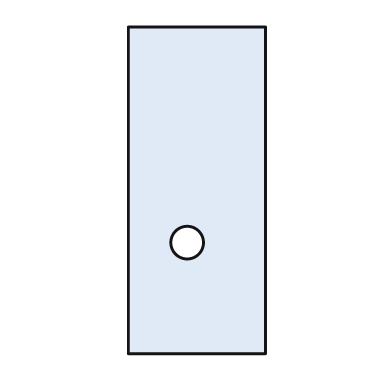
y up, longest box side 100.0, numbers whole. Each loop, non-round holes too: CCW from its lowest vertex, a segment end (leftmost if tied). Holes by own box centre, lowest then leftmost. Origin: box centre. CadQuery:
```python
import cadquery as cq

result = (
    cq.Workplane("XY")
    .moveTo(-21.0, -50.0)
    .lineTo(21.0, -50.0)
    .lineTo(21.0, 50.0)
    .lineTo(-21.0, 50.0)
    .close()
    .moveTo(-3.0, -16.0)
    .circle(5.0)
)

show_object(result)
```